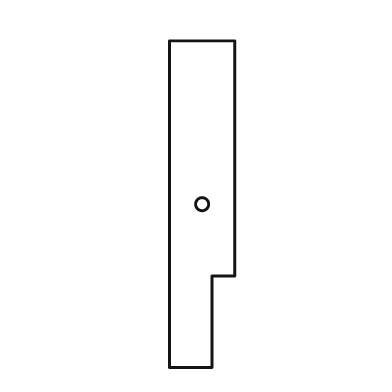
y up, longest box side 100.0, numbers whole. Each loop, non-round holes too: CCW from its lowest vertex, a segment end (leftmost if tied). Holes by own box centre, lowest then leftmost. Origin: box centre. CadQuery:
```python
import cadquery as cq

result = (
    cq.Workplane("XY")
    .moveTo(-10.0, -50.0)
    .lineTo(3.0, -50.0)
    .lineTo(3.0, -22.0)
    .lineTo(10.0, -22.0)
    .lineTo(10.0, 50.0)
    .lineTo(-10.0, 50.0)
    .close()
    .moveTo(0.0, 0.0)
    .circle(2.0)
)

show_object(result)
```